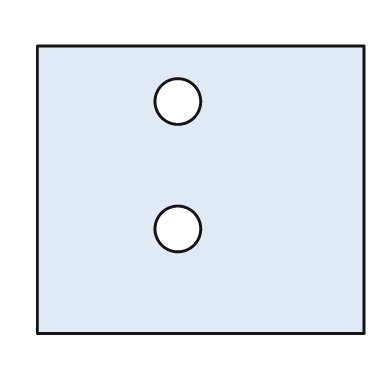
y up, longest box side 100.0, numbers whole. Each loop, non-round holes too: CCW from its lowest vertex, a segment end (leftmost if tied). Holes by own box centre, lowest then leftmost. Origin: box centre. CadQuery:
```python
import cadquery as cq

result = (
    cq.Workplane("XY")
    .moveTo(-50.0, -44.0)
    .lineTo(50.0, -44.0)
    .lineTo(50.0, 44.0)
    .lineTo(-50.0, 44.0)
    .close()
    .moveTo(-7.0, -12.0)
    .circle(7.0)
    .moveTo(-7.0, 27.0)
    .circle(7.0)
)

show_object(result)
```